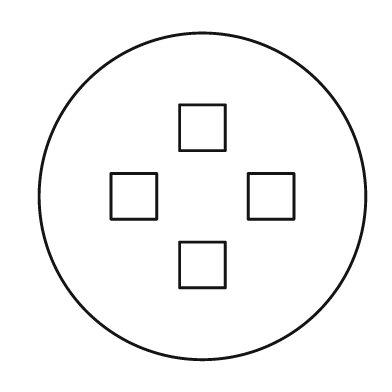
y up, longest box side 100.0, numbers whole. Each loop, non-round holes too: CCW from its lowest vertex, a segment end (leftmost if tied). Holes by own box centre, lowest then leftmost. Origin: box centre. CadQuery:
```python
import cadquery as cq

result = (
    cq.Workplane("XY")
    .moveTo(0.0, 0.0)
    .circle(50.0)
    .moveTo(-7.0, -28.0)
    .lineTo(7.0, -28.0)
    .lineTo(7.0, -14.0)
    .lineTo(-7.0, -14.0)
    .close()
    .moveTo(-28.0, -7.0)
    .lineTo(-14.0, -7.0)
    .lineTo(-14.0, 7.0)
    .lineTo(-28.0, 7.0)
    .close()
    .moveTo(14.0, -7.0)
    .lineTo(28.0, -7.0)
    .lineTo(28.0, 7.0)
    .lineTo(14.0, 7.0)
    .close()
    .moveTo(-7.0, 14.0)
    .lineTo(7.0, 14.0)
    .lineTo(7.0, 28.0)
    .lineTo(-7.0, 28.0)
    .close()
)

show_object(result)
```